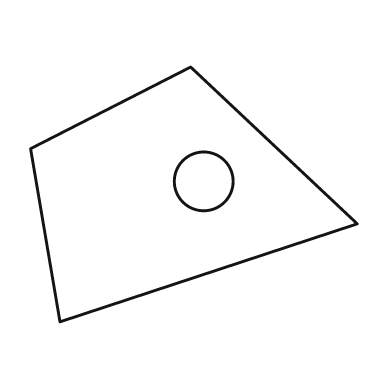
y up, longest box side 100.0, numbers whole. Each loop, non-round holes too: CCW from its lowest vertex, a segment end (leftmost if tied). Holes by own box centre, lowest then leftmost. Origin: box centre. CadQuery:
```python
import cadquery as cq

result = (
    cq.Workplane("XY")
    .moveTo(-41.0, -39.0)
    .lineTo(50.0, -9.0)
    .lineTo(-1.0, 39.0)
    .lineTo(-50.0, 14.0)
    .close()
    .moveTo(3.0, 4.0)
    .circle(9.0)
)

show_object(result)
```